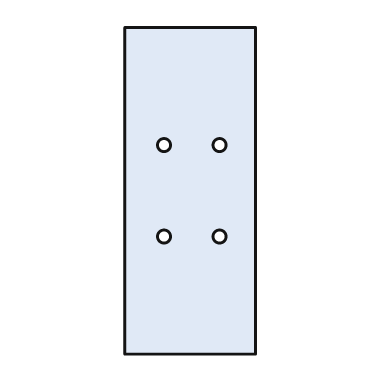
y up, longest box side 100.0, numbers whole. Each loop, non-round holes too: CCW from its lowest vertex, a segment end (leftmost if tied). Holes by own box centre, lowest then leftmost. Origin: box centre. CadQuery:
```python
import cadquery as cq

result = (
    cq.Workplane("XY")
    .moveTo(-20.0, -50.0)
    .lineTo(20.0, -50.0)
    .lineTo(20.0, 50.0)
    .lineTo(-20.0, 50.0)
    .close()
    .moveTo(-8.0, -14.0)
    .circle(2.0)
    .moveTo(9.0, -14.0)
    .circle(2.0)
    .moveTo(-8.0, 14.0)
    .circle(2.0)
    .moveTo(9.0, 14.0)
    .circle(2.0)
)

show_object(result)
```